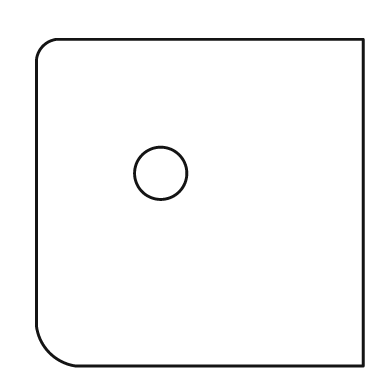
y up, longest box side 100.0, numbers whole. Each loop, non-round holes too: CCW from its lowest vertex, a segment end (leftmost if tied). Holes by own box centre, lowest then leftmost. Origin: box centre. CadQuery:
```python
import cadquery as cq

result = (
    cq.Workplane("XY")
    .moveTo(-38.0, -50.0)
    .lineTo(50.0, -50.0)
    .lineTo(50.0, 50.0)
    .lineTo(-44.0, 50.0)
    .threePointArc((-48.0, 48.0), (-50.0, 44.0))
    .lineTo(-50.0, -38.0)
    .threePointArc((-46.0, -46.0), (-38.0, -50.0))
    .close()
    .moveTo(-12.0, 9.0)
    .circle(8.0)
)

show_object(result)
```